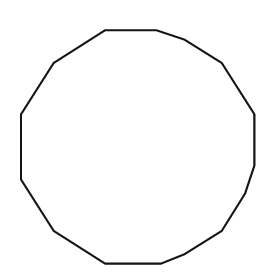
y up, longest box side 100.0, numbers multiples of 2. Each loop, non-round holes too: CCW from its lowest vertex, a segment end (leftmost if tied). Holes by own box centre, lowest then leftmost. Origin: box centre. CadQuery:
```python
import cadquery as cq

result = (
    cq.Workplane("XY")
    .moveTo(-14.0, -50.0)
    .lineTo(10.0, -50.0)
    .lineTo(20.0, -46.0)
    .lineTo(36.0, -36.0)
    .lineTo(46.0, -20.0)
    .lineTo(50.0, -8.0)
    .lineTo(50.0, 14.0)
    .lineTo(36.0, 36.0)
    .lineTo(20.0, 46.0)
    .lineTo(8.0, 50.0)
    .lineTo(-14.0, 50.0)
    .lineTo(-36.0, 36.0)
    .lineTo(-50.0, 14.0)
    .lineTo(-50.0, -14.0)
    .lineTo(-36.0, -36.0)
    .close()
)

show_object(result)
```